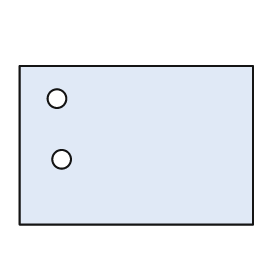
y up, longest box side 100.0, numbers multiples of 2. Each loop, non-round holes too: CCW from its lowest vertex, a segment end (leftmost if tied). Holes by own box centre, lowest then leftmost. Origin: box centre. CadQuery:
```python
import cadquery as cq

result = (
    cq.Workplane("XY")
    .moveTo(-50.0, -34.0)
    .lineTo(50.0, -34.0)
    .lineTo(50.0, 34.0)
    .lineTo(-50.0, 34.0)
    .close()
    .moveTo(-32.0, -6.0)
    .circle(4.0)
    .moveTo(-34.0, 20.0)
    .circle(4.0)
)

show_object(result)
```